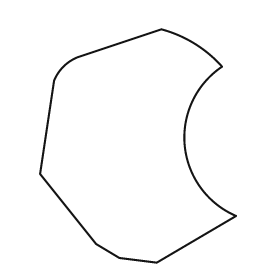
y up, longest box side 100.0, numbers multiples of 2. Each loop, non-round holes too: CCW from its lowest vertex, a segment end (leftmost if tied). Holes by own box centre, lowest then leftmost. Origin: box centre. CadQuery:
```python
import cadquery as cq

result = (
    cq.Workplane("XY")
    .moveTo(8.0, -50.0)
    .lineTo(42.0, -30.0)
    .threePointArc((20.0, 0.0), (36.0, 34.0))
    .threePointArc((24.0, 44.0), (10.0, 50.0))
    .lineTo(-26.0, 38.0)
    .threePointArc((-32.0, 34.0), (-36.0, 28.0))
    .lineTo(-42.0, -12.0)
    .lineTo(-18.0, -42.0)
    .lineTo(-8.0, -48.0)
    .close()
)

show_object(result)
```